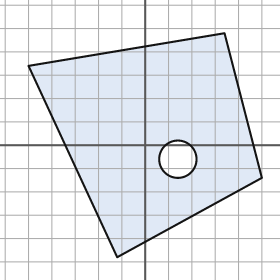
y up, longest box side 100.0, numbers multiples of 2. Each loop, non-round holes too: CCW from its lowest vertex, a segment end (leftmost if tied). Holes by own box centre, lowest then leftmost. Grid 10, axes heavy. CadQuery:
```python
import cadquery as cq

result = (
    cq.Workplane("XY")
    .moveTo(-12.0, -48.0)
    .lineTo(50.0, -14.0)
    .lineTo(34.0, 48.0)
    .lineTo(-50.0, 34.0)
    .close()
    .moveTo(14.0, -6.0)
    .circle(8.0)
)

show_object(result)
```